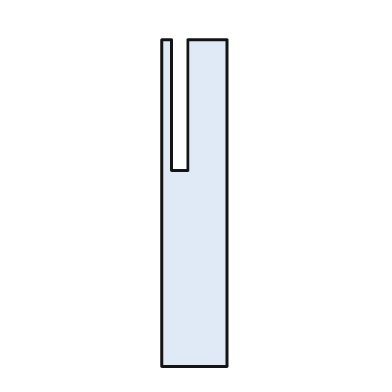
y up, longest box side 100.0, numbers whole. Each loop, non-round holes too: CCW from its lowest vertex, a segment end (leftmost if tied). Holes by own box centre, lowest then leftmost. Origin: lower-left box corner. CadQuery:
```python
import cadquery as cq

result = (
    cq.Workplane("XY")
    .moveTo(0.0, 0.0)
    .lineTo(20.0, 0.0)
    .lineTo(20.0, 100.0)
    .lineTo(8.0, 100.0)
    .lineTo(8.0, 60.0)
    .lineTo(3.0, 60.0)
    .lineTo(3.0, 100.0)
    .lineTo(0.0, 100.0)
    .close()
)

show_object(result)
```